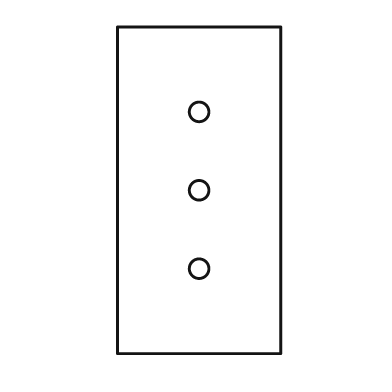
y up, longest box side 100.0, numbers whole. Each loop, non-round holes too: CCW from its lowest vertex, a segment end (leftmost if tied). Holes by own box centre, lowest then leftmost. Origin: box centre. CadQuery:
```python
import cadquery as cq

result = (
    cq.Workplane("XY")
    .moveTo(-25.0, -50.0)
    .lineTo(25.0, -50.0)
    .lineTo(25.0, 50.0)
    .lineTo(-25.0, 50.0)
    .close()
    .moveTo(0.0, -24.0)
    .circle(3.0)
    .moveTo(0.0, 0.0)
    .circle(3.0)
    .moveTo(0.0, 24.0)
    .circle(3.0)
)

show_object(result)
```